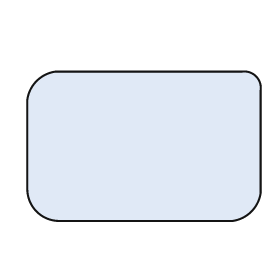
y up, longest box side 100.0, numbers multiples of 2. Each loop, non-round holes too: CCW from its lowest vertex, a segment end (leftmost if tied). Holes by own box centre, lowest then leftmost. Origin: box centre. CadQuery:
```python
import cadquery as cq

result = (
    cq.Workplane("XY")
    .moveTo(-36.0, -32.0)
    .lineTo(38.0, -32.0)
    .threePointArc((46.0, -28.0), (50.0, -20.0))
    .lineTo(50.0, 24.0)
    .threePointArc((48.0, 30.0), (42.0, 32.0))
    .lineTo(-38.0, 32.0)
    .threePointArc((-46.0, 28.0), (-50.0, 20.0))
    .lineTo(-50.0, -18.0)
    .threePointArc((-46.0, -28.0), (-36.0, -32.0))
    .close()
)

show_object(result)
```